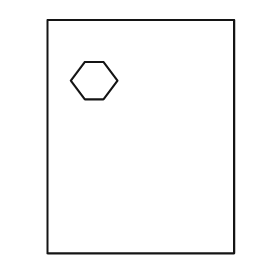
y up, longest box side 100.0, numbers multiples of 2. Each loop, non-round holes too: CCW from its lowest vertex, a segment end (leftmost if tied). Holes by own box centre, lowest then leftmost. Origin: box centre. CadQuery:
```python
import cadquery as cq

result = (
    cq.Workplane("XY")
    .moveTo(-40.0, -50.0)
    .lineTo(40.0, -50.0)
    .lineTo(40.0, 50.0)
    .lineTo(-40.0, 50.0)
    .close()
    .moveTo(-24.0, 16.0)
    .lineTo(-16.0, 16.0)
    .lineTo(-10.0, 24.0)
    .lineTo(-16.0, 32.0)
    .lineTo(-24.0, 32.0)
    .lineTo(-30.0, 24.0)
    .close()
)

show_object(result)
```